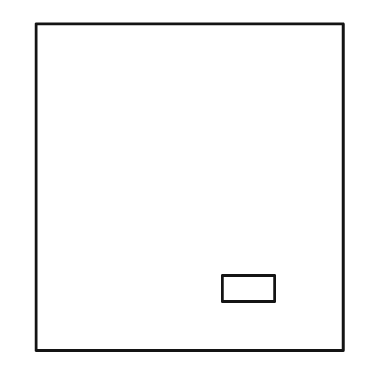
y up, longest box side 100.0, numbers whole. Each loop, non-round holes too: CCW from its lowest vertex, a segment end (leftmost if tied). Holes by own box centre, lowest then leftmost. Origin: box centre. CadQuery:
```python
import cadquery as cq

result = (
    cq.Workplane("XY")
    .moveTo(-47.0, -50.0)
    .lineTo(47.0, -50.0)
    .lineTo(47.0, 50.0)
    .lineTo(-47.0, 50.0)
    .close()
    .moveTo(10.0, -35.0)
    .lineTo(26.0, -35.0)
    .lineTo(26.0, -27.0)
    .lineTo(10.0, -27.0)
    .close()
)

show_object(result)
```